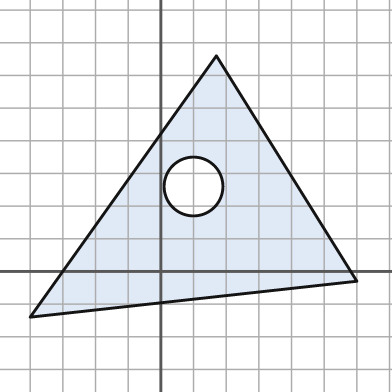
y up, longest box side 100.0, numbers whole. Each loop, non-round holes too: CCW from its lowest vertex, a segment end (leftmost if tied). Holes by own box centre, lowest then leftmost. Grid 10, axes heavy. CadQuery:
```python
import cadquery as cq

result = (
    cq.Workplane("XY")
    .moveTo(-40.0, -14.0)
    .lineTo(60.0, -3.0)
    .lineTo(17.0, 66.0)
    .close()
    .moveTo(10.0, 26.0)
    .circle(9.0)
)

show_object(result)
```